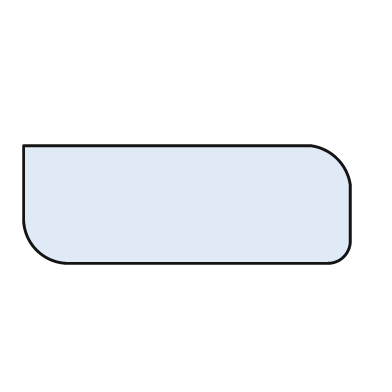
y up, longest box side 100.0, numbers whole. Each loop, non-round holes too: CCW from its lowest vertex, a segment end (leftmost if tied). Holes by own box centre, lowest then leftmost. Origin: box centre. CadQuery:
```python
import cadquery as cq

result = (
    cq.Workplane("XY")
    .moveTo(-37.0, -18.0)
    .lineTo(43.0, -18.0)
    .threePointArc((48.0, -16.0), (50.0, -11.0))
    .lineTo(50.0, 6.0)
    .threePointArc((46.0, 14.0), (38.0, 18.0))
    .lineTo(-50.0, 18.0)
    .lineTo(-50.0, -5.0)
    .threePointArc((-46.0, -14.0), (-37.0, -18.0))
    .close()
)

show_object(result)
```